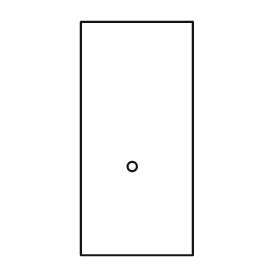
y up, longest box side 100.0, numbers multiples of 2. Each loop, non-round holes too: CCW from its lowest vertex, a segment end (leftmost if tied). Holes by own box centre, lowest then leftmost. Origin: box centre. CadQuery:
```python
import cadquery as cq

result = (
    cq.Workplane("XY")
    .moveTo(-24.0, -50.0)
    .lineTo(24.0, -50.0)
    .lineTo(24.0, 50.0)
    .lineTo(-24.0, 50.0)
    .close()
    .moveTo(-2.0, -12.0)
    .circle(2.0)
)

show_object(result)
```